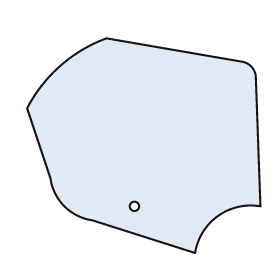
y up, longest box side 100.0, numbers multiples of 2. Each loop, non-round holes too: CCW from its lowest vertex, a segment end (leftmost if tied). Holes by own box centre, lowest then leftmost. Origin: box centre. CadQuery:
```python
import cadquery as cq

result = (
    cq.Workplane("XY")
    .moveTo(22.0, -46.0)
    .threePointArc((32.0, -30.0), (50.0, -26.0))
    .lineTo(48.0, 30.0)
    .threePointArc((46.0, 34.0), (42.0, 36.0))
    .lineTo(-16.0, 46.0)
    .threePointArc((-36.0, 34.0), (-50.0, 16.0))
    .lineTo(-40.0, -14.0)
    .threePointArc((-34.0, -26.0), (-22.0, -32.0))
    .close()
    .moveTo(-4.0, -26.0)
    .circle(2.0)
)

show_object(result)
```